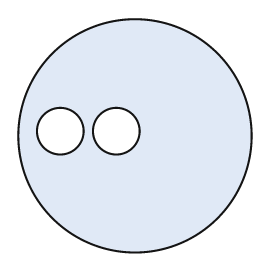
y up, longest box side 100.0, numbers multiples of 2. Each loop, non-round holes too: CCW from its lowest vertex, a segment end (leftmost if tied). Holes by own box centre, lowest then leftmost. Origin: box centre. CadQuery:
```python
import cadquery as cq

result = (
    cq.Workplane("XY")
    .moveTo(0.0, 0.0)
    .circle(50.0)
    .moveTo(-32.0, 2.0)
    .circle(10.0)
    .moveTo(-8.0, 2.0)
    .circle(10.0)
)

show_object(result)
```